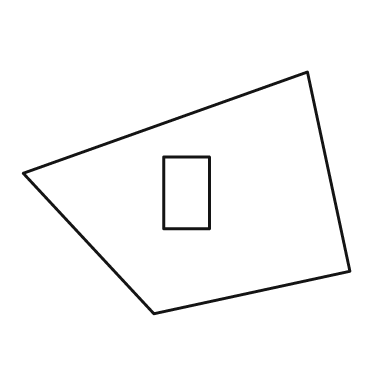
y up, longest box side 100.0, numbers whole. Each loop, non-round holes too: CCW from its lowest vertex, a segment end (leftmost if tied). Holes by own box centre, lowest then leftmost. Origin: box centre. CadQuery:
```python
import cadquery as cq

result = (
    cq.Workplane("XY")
    .moveTo(-10.0, -37.0)
    .lineTo(50.0, -24.0)
    .lineTo(37.0, 37.0)
    .lineTo(-50.0, 6.0)
    .close()
    .moveTo(-7.0, -11.0)
    .lineTo(7.0, -11.0)
    .lineTo(7.0, 11.0)
    .lineTo(-7.0, 11.0)
    .close()
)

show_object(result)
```